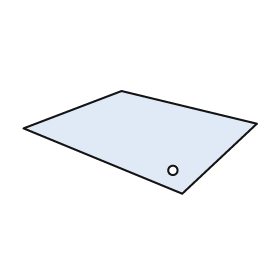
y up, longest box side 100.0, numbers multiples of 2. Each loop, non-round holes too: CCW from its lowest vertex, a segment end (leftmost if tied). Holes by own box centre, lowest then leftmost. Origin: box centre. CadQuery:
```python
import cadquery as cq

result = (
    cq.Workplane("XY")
    .moveTo(18.0, -22.0)
    .lineTo(50.0, 8.0)
    .lineTo(-8.0, 22.0)
    .lineTo(-50.0, 6.0)
    .close()
    .moveTo(14.0, -12.0)
    .circle(2.0)
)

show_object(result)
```